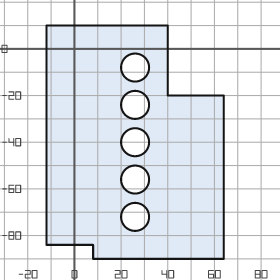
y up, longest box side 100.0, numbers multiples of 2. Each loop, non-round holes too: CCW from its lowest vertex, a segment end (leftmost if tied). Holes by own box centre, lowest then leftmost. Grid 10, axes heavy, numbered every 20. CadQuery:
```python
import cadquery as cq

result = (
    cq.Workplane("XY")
    .moveTo(8.0, -90.0)
    .lineTo(64.0, -90.0)
    .lineTo(64.0, -20.0)
    .lineTo(40.0, -20.0)
    .lineTo(40.0, 10.0)
    .lineTo(-12.0, 10.0)
    .lineTo(-12.0, -84.0)
    .lineTo(8.0, -84.0)
    .close()
    .moveTo(26.0, -72.0)
    .circle(6.0)
    .moveTo(26.0, -56.0)
    .circle(6.0)
    .moveTo(26.0, -40.0)
    .circle(6.0)
    .moveTo(26.0, -24.0)
    .circle(6.0)
    .moveTo(26.0, -8.0)
    .circle(6.0)
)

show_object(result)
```